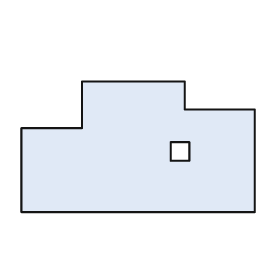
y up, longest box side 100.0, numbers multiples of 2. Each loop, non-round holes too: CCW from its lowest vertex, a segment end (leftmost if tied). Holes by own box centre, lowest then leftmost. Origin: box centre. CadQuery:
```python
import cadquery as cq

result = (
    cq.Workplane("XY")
    .moveTo(-50.0, -28.0)
    .lineTo(50.0, -28.0)
    .lineTo(50.0, 16.0)
    .lineTo(20.0, 16.0)
    .lineTo(20.0, 28.0)
    .lineTo(-24.0, 28.0)
    .lineTo(-24.0, 8.0)
    .lineTo(-50.0, 8.0)
    .close()
    .moveTo(14.0, -6.0)
    .lineTo(22.0, -6.0)
    .lineTo(22.0, 2.0)
    .lineTo(14.0, 2.0)
    .close()
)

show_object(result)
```